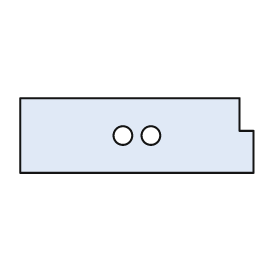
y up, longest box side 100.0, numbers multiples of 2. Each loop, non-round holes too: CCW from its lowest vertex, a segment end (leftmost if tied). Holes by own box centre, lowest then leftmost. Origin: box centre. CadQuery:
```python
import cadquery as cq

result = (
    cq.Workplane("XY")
    .moveTo(-50.0, -16.0)
    .lineTo(50.0, -16.0)
    .lineTo(50.0, 2.0)
    .lineTo(44.0, 2.0)
    .lineTo(44.0, 16.0)
    .lineTo(-50.0, 16.0)
    .close()
    .moveTo(-6.0, 0.0)
    .circle(4.0)
    .moveTo(6.0, 0.0)
    .circle(4.0)
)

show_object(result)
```